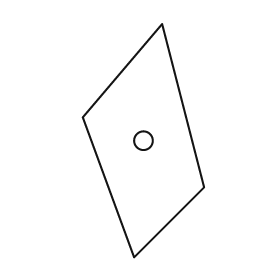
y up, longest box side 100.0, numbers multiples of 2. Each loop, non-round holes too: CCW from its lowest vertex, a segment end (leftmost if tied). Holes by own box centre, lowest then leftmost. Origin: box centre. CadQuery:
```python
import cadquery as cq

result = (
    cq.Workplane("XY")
    .moveTo(-4.0, -50.0)
    .lineTo(26.0, -20.0)
    .lineTo(8.0, 50.0)
    .lineTo(-26.0, 10.0)
    .close()
    .moveTo(0.0, 0.0)
    .circle(4.0)
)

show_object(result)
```